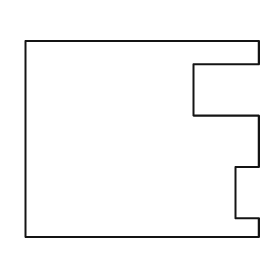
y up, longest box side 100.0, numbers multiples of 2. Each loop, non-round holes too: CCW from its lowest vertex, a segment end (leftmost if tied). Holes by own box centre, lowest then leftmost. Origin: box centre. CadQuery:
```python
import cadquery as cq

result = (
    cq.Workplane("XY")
    .moveTo(-50.0, -42.0)
    .lineTo(50.0, -42.0)
    .lineTo(50.0, -34.0)
    .lineTo(40.0, -34.0)
    .lineTo(40.0, -12.0)
    .lineTo(50.0, -12.0)
    .lineTo(50.0, 10.0)
    .lineTo(22.0, 10.0)
    .lineTo(22.0, 32.0)
    .lineTo(50.0, 32.0)
    .lineTo(50.0, 42.0)
    .lineTo(-50.0, 42.0)
    .close()
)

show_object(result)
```